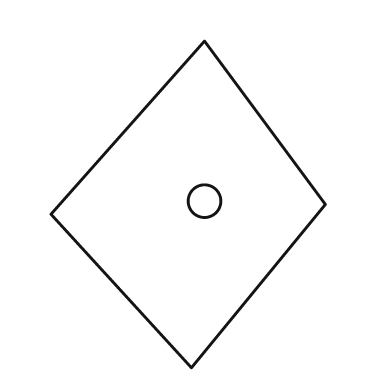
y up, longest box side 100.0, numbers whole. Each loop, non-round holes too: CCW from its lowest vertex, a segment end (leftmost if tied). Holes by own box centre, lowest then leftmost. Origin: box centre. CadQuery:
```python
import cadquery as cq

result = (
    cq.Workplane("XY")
    .moveTo(1.0, -50.0)
    .lineTo(42.0, 0.0)
    .lineTo(5.0, 50.0)
    .lineTo(-42.0, -3.0)
    .close()
    .moveTo(5.0, 1.0)
    .circle(5.0)
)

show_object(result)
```